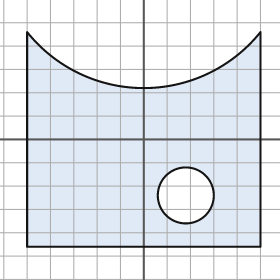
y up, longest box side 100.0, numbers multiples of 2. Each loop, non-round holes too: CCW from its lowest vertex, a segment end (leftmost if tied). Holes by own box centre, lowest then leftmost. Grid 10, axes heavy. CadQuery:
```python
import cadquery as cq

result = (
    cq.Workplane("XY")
    .moveTo(-50.0, -46.0)
    .lineTo(50.0, -46.0)
    .lineTo(50.0, 46.0)
    .threePointArc((0.0, 22.0), (-50.0, 46.0))
    .close()
    .moveTo(18.0, -24.0)
    .circle(12.0)
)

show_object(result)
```